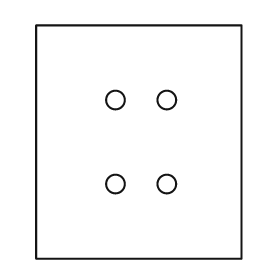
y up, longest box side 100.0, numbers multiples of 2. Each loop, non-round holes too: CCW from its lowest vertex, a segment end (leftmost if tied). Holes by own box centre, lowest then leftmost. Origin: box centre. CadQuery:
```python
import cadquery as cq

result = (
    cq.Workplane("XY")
    .moveTo(-44.0, -50.0)
    .lineTo(44.0, -50.0)
    .lineTo(44.0, 50.0)
    .lineTo(-44.0, 50.0)
    .close()
    .moveTo(-10.0, -18.0)
    .circle(4.0)
    .moveTo(12.0, -18.0)
    .circle(4.0)
    .moveTo(-10.0, 18.0)
    .circle(4.0)
    .moveTo(12.0, 18.0)
    .circle(4.0)
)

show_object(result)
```